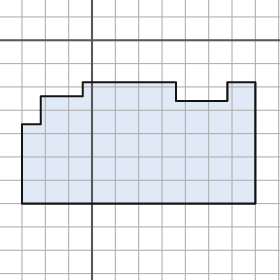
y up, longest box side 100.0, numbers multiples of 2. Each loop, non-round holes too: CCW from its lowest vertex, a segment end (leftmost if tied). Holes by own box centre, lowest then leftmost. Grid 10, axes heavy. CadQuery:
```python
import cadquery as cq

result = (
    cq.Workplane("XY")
    .moveTo(-30.0, -70.0)
    .lineTo(70.0, -70.0)
    .lineTo(70.0, -18.0)
    .lineTo(58.0, -18.0)
    .lineTo(58.0, -26.0)
    .lineTo(36.0, -26.0)
    .lineTo(36.0, -18.0)
    .lineTo(-4.0, -18.0)
    .lineTo(-4.0, -24.0)
    .lineTo(-22.0, -24.0)
    .lineTo(-22.0, -36.0)
    .lineTo(-30.0, -36.0)
    .close()
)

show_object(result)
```